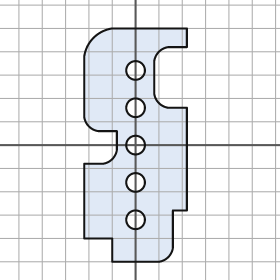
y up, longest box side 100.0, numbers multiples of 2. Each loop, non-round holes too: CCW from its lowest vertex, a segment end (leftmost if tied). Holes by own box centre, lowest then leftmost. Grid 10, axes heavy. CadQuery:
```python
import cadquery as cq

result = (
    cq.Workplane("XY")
    .moveTo(-10.0, -50.0)
    .lineTo(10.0, -50.0)
    .threePointArc((14.0, -48.0), (16.0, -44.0))
    .lineTo(16.0, -28.0)
    .lineTo(22.0, -28.0)
    .lineTo(22.0, 16.0)
    .lineTo(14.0, 16.0)
    .threePointArc((10.0, 18.0), (8.0, 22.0))
    .lineTo(8.0, 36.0)
    .threePointArc((10.0, 40.0), (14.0, 42.0))
    .lineTo(22.0, 42.0)
    .lineTo(22.0, 50.0)
    .lineTo(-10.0, 50.0)
    .threePointArc((-18.0, 46.0), (-22.0, 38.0))
    .lineTo(-22.0, 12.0)
    .threePointArc((-20.0, 8.0), (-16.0, 6.0))
    .lineTo(-8.0, 6.0)
    .lineTo(-8.0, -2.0)
    .threePointArc((-10.0, -6.0), (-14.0, -8.0))
    .lineTo(-22.0, -8.0)
    .lineTo(-22.0, -40.0)
    .lineTo(-10.0, -40.0)
    .close()
    .moveTo(0.0, -32.0)
    .circle(4.0)
    .moveTo(0.0, -16.0)
    .circle(4.0)
    .moveTo(0.0, 0.0)
    .circle(4.0)
    .moveTo(0.0, 16.0)
    .circle(4.0)
    .moveTo(0.0, 32.0)
    .circle(4.0)
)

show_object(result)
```